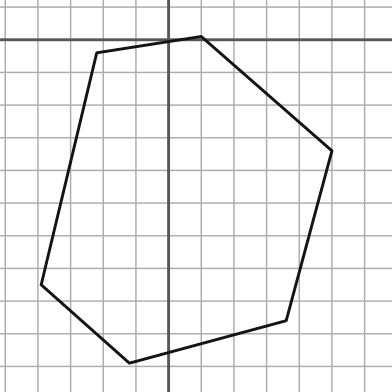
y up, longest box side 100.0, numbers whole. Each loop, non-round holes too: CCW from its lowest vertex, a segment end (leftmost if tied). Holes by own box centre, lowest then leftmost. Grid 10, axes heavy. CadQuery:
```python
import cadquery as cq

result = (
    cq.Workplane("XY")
    .moveTo(-12.0, -99.0)
    .lineTo(36.0, -86.0)
    .lineTo(50.0, -34.0)
    .lineTo(10.0, 1.0)
    .lineTo(-22.0, -4.0)
    .lineTo(-39.0, -75.0)
    .close()
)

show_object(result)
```